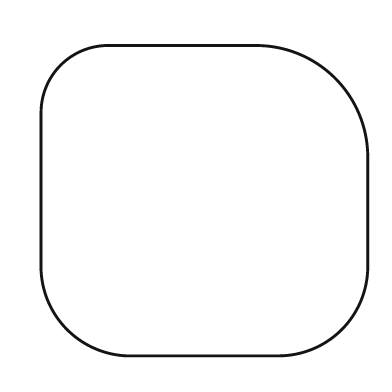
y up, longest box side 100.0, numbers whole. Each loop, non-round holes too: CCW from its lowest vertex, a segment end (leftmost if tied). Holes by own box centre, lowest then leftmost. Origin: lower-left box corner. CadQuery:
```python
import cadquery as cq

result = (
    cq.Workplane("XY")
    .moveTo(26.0, 0.0)
    .lineTo(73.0, 0.0)
    .threePointArc((92.0, 8.0), (100.0, 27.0))
    .lineTo(100.0, 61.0)
    .threePointArc((90.0, 85.0), (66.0, 95.0))
    .lineTo(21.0, 95.0)
    .threePointArc((6.0, 89.0), (0.0, 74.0))
    .lineTo(0.0, 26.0)
    .threePointArc((8.0, 8.0), (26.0, 0.0))
    .close()
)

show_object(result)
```